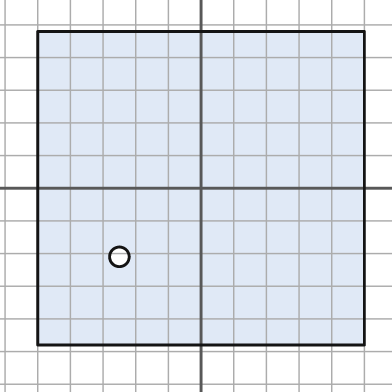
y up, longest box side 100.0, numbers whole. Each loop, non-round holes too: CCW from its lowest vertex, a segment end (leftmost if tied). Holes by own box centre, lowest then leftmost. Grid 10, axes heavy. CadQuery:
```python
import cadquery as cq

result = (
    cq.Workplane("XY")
    .moveTo(-50.0, -48.0)
    .lineTo(50.0, -48.0)
    .lineTo(50.0, 48.0)
    .lineTo(-50.0, 48.0)
    .close()
    .moveTo(-25.0, -21.0)
    .circle(3.0)
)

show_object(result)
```